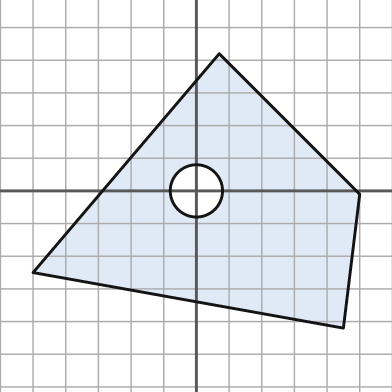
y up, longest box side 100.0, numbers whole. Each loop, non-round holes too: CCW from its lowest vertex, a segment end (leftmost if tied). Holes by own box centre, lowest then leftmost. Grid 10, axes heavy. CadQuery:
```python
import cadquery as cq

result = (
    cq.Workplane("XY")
    .moveTo(45.0, -42.0)
    .lineTo(50.0, -1.0)
    .lineTo(7.0, 42.0)
    .lineTo(-50.0, -25.0)
    .close()
    .moveTo(0.0, 0.0)
    .circle(8.0)
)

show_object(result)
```